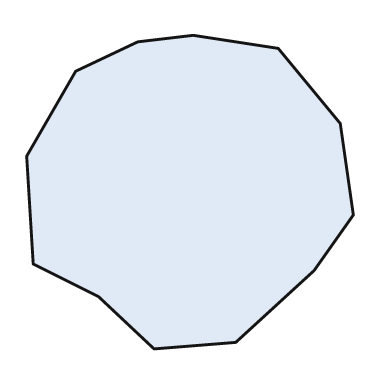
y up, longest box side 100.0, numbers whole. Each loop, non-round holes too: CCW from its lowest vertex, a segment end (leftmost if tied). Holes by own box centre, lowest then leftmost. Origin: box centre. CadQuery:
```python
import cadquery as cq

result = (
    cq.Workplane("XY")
    .moveTo(-11.0, -48.0)
    .lineTo(14.0, -46.0)
    .lineTo(38.0, -24.0)
    .lineTo(50.0, -7.0)
    .lineTo(46.0, 21.0)
    .lineTo(27.0, 44.0)
    .lineTo(1.0, 48.0)
    .lineTo(-16.0, 46.0)
    .lineTo(-35.0, 37.0)
    .lineTo(-50.0, 11.0)
    .lineTo(-48.0, -22.0)
    .lineTo(-28.0, -32.0)
    .close()
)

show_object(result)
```